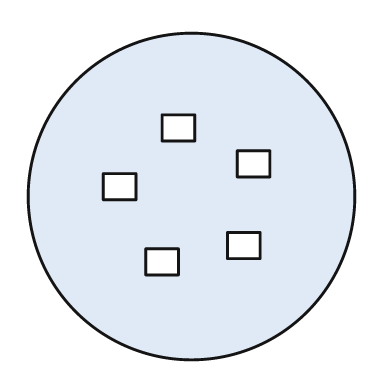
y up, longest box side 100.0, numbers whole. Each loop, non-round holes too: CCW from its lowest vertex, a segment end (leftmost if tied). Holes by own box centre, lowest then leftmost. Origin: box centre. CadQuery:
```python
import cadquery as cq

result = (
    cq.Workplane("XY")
    .moveTo(0.0, 0.0)
    .circle(50.0)
    .moveTo(-14.0, -24.0)
    .lineTo(-4.0, -24.0)
    .lineTo(-4.0, -16.0)
    .lineTo(-14.0, -16.0)
    .close()
    .moveTo(11.0, -19.0)
    .lineTo(21.0, -19.0)
    .lineTo(21.0, -11.0)
    .lineTo(11.0, -11.0)
    .close()
    .moveTo(-27.0, -1.0)
    .lineTo(-17.0, -1.0)
    .lineTo(-17.0, 7.0)
    .lineTo(-27.0, 7.0)
    .close()
    .moveTo(14.0, 6.0)
    .lineTo(24.0, 6.0)
    .lineTo(24.0, 14.0)
    .lineTo(14.0, 14.0)
    .close()
    .moveTo(-9.0, 17.0)
    .lineTo(1.0, 17.0)
    .lineTo(1.0, 25.0)
    .lineTo(-9.0, 25.0)
    .close()
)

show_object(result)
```